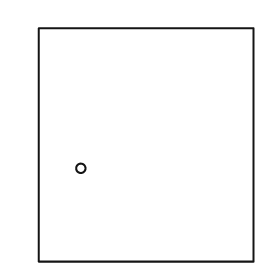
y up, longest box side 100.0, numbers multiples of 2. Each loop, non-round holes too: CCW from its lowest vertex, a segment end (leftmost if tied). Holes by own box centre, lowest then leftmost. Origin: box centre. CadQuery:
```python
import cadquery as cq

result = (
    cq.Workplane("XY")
    .moveTo(-46.0, -50.0)
    .lineTo(46.0, -50.0)
    .lineTo(46.0, 50.0)
    .lineTo(-46.0, 50.0)
    .close()
    .moveTo(-28.0, -10.0)
    .circle(2.0)
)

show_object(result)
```